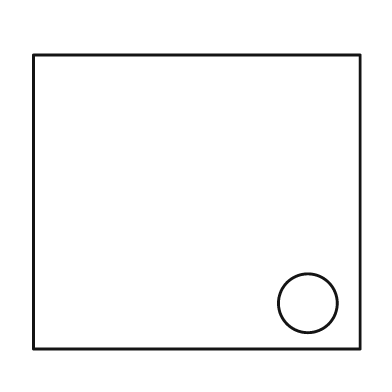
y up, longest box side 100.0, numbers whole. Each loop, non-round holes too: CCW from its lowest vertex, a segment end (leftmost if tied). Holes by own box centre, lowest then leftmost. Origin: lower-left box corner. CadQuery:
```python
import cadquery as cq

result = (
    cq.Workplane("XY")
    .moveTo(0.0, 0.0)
    .lineTo(100.0, 0.0)
    .lineTo(100.0, 90.0)
    .lineTo(0.0, 90.0)
    .close()
    .moveTo(84.0, 14.0)
    .circle(9.0)
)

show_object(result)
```